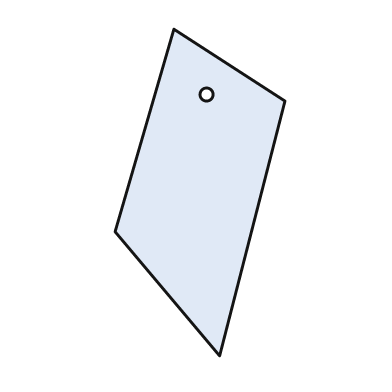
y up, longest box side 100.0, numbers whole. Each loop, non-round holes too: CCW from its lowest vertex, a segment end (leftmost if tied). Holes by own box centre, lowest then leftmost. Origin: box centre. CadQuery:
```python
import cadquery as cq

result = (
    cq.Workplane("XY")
    .moveTo(6.0, -50.0)
    .lineTo(26.0, 28.0)
    .lineTo(-8.0, 50.0)
    .lineTo(-26.0, -12.0)
    .close()
    .moveTo(2.0, 30.0)
    .circle(2.0)
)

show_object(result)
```